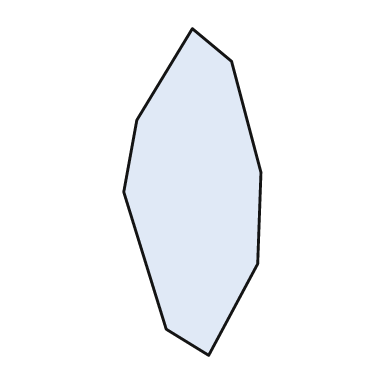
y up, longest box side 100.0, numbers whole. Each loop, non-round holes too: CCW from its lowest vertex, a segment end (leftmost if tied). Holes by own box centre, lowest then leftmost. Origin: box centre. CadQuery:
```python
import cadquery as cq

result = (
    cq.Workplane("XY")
    .moveTo(5.0, -50.0)
    .lineTo(20.0, -22.0)
    .lineTo(21.0, 6.0)
    .lineTo(12.0, 40.0)
    .lineTo(0.0, 50.0)
    .lineTo(-17.0, 22.0)
    .lineTo(-21.0, 0.0)
    .lineTo(-8.0, -42.0)
    .close()
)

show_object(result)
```